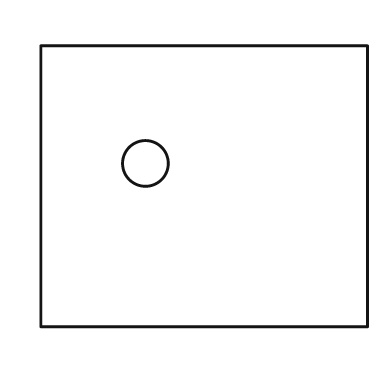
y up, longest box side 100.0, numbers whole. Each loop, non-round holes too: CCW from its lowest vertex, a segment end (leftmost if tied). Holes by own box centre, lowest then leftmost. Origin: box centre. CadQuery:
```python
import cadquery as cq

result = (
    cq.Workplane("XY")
    .moveTo(-50.0, -43.0)
    .lineTo(50.0, -43.0)
    .lineTo(50.0, 43.0)
    .lineTo(-50.0, 43.0)
    .close()
    .moveTo(-18.0, 7.0)
    .circle(7.0)
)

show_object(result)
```